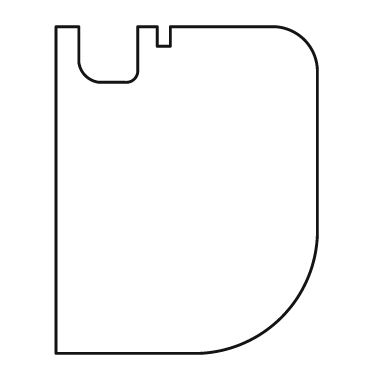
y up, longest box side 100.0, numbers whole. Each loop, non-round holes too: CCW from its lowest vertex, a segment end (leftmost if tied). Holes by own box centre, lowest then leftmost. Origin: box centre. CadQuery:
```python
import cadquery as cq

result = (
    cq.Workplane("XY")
    .moveTo(-40.0, -50.0)
    .lineTo(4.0, -50.0)
    .threePointArc((29.0, -39.0), (40.0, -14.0))
    .lineTo(40.0, 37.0)
    .threePointArc((36.0, 46.0), (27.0, 50.0))
    .lineTo(-5.0, 50.0)
    .lineTo(-5.0, 44.0)
    .lineTo(-9.0, 44.0)
    .lineTo(-9.0, 50.0)
    .lineTo(-15.0, 50.0)
    .lineTo(-15.0, 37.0)
    .threePointArc((-16.0, 34.0), (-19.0, 33.0))
    .lineTo(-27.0, 33.0)
    .threePointArc((-31.0, 35.0), (-33.0, 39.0))
    .lineTo(-33.0, 50.0)
    .lineTo(-40.0, 50.0)
    .close()
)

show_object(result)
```